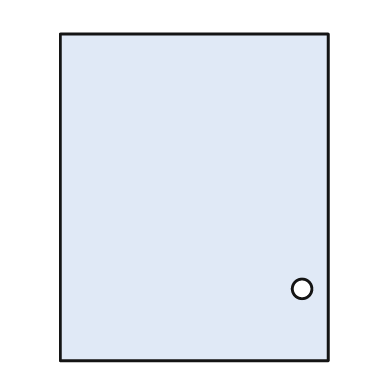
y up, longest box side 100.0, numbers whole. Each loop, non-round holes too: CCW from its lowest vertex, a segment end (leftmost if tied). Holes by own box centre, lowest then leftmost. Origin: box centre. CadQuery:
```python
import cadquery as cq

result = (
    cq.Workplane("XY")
    .moveTo(-41.0, -50.0)
    .lineTo(41.0, -50.0)
    .lineTo(41.0, 50.0)
    .lineTo(-41.0, 50.0)
    .close()
    .moveTo(33.0, -28.0)
    .circle(3.0)
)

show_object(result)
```